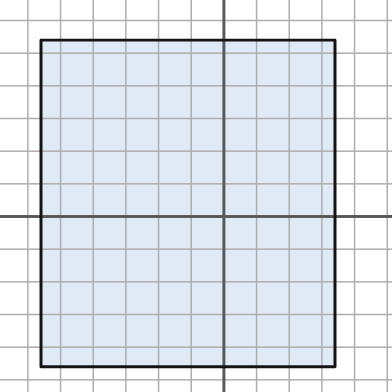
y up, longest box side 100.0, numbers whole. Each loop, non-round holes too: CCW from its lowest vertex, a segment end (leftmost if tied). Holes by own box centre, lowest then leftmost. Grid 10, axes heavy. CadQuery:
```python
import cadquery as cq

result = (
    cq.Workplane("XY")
    .moveTo(-56.0, -46.0)
    .lineTo(34.0, -46.0)
    .lineTo(34.0, 54.0)
    .lineTo(-56.0, 54.0)
    .close()
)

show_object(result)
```